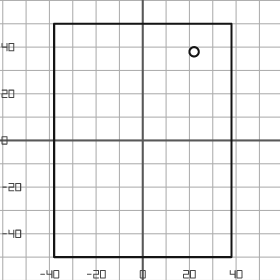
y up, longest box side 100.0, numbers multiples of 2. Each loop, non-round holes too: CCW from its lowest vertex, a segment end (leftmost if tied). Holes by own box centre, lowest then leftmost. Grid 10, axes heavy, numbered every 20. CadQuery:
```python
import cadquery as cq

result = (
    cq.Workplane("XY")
    .moveTo(-38.0, -50.0)
    .lineTo(38.0, -50.0)
    .lineTo(38.0, 50.0)
    .lineTo(-38.0, 50.0)
    .close()
    .moveTo(22.0, 38.0)
    .circle(2.0)
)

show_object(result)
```